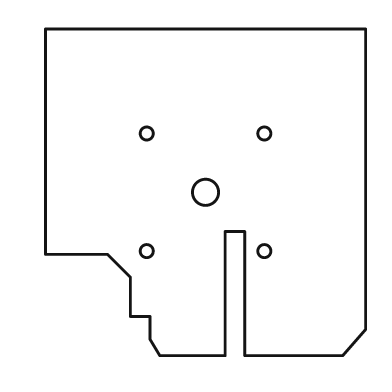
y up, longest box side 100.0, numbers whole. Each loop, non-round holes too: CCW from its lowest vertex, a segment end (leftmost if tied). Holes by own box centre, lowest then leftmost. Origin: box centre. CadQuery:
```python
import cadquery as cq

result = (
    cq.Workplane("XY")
    .moveTo(-14.0, -50.0)
    .lineTo(6.0, -50.0)
    .lineTo(6.0, -12.0)
    .lineTo(12.0, -12.0)
    .lineTo(12.0, -50.0)
    .lineTo(42.0, -50.0)
    .lineTo(49.0, -42.0)
    .lineTo(49.0, 50.0)
    .lineTo(-49.0, 50.0)
    .lineTo(-49.0, -19.0)
    .lineTo(-30.0, -19.0)
    .lineTo(-23.0, -26.0)
    .lineTo(-23.0, -38.0)
    .lineTo(-17.0, -38.0)
    .lineTo(-17.0, -45.0)
    .close()
    .moveTo(-18.0, -18.0)
    .circle(2.0)
    .moveTo(18.0, -18.0)
    .circle(2.0)
    .moveTo(0.0, 0.0)
    .circle(4.0)
    .moveTo(-18.0, 18.0)
    .circle(2.0)
    .moveTo(18.0, 18.0)
    .circle(2.0)
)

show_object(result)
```